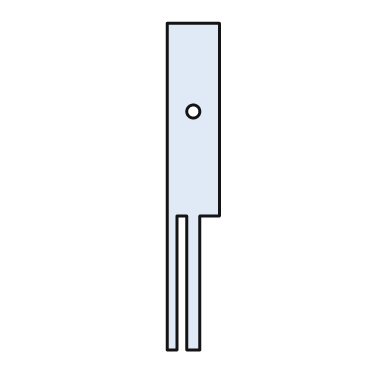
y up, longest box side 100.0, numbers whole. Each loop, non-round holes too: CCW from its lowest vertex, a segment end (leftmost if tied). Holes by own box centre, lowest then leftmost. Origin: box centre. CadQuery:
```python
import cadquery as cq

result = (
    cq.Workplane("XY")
    .moveTo(-8.0, -50.0)
    .lineTo(-5.0, -50.0)
    .lineTo(-5.0, -9.0)
    .lineTo(-2.0, -9.0)
    .lineTo(-2.0, -50.0)
    .lineTo(2.0, -50.0)
    .lineTo(2.0, -9.0)
    .lineTo(8.0, -9.0)
    .lineTo(8.0, 50.0)
    .lineTo(-8.0, 50.0)
    .close()
    .moveTo(0.0, 23.0)
    .circle(2.0)
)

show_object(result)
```